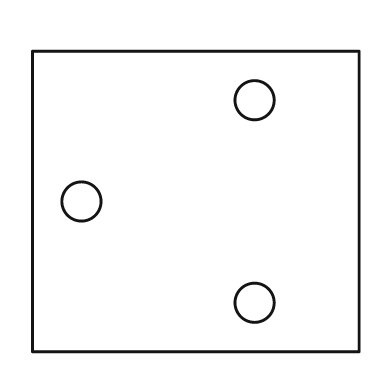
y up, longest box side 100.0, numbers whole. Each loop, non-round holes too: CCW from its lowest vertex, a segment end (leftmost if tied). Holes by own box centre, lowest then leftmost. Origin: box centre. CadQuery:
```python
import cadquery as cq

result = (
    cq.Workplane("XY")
    .moveTo(-50.0, -46.0)
    .lineTo(50.0, -46.0)
    .lineTo(50.0, 46.0)
    .lineTo(-50.0, 46.0)
    .close()
    .moveTo(18.0, -31.0)
    .circle(6.0)
    .moveTo(-35.0, 0.0)
    .circle(6.0)
    .moveTo(18.0, 31.0)
    .circle(6.0)
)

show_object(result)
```